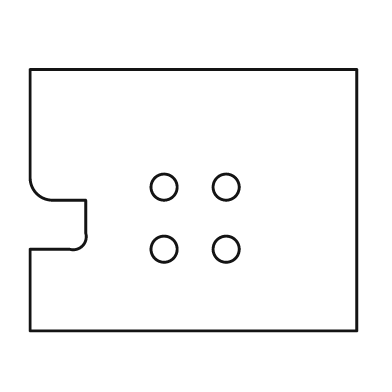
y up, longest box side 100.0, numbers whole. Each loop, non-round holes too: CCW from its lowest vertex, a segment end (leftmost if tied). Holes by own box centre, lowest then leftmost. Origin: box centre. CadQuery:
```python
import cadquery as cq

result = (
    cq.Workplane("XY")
    .moveTo(-50.0, -40.0)
    .lineTo(50.0, -40.0)
    .lineTo(50.0, 40.0)
    .lineTo(-50.0, 40.0)
    .lineTo(-50.0, 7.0)
    .threePointArc((-48.0, 2.0), (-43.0, 0.0))
    .lineTo(-33.0, 0.0)
    .lineTo(-33.0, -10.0)
    .threePointArc((-34.0, -14.0), (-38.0, -15.0))
    .lineTo(-50.0, -15.0)
    .close()
    .moveTo(-9.0, -15.0)
    .circle(4.0)
    .moveTo(10.0, -15.0)
    .circle(4.0)
    .moveTo(-9.0, 4.0)
    .circle(4.0)
    .moveTo(10.0, 4.0)
    .circle(4.0)
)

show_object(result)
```